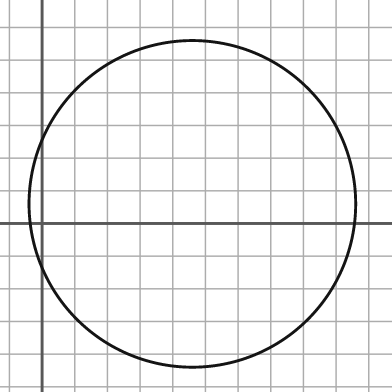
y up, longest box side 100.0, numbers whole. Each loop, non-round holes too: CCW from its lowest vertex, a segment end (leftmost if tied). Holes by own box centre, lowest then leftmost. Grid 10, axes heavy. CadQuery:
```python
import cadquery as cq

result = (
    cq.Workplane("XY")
    .moveTo(46.0, 6.0)
    .circle(50.0)
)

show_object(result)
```